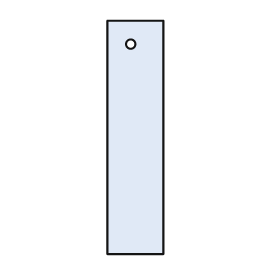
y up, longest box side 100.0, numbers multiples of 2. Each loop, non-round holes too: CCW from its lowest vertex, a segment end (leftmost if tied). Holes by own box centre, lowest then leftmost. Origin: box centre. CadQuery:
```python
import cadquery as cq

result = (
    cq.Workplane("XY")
    .moveTo(-12.0, -50.0)
    .lineTo(12.0, -50.0)
    .lineTo(12.0, 50.0)
    .lineTo(-12.0, 50.0)
    .close()
    .moveTo(-2.0, 40.0)
    .circle(2.0)
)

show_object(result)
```